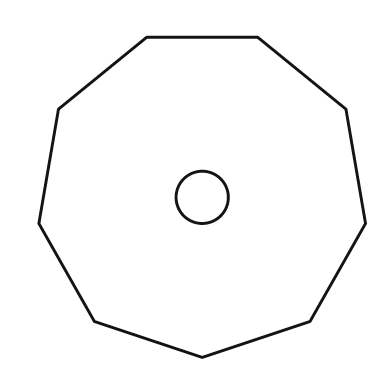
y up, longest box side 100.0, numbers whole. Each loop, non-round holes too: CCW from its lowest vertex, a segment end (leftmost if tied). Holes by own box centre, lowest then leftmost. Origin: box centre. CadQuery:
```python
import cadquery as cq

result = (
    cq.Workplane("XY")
    .moveTo(0.0, -49.0)
    .lineTo(33.0, -38.0)
    .lineTo(50.0, -8.0)
    .lineTo(44.0, 27.0)
    .lineTo(17.0, 49.0)
    .lineTo(-17.0, 49.0)
    .lineTo(-44.0, 27.0)
    .lineTo(-50.0, -8.0)
    .lineTo(-33.0, -38.0)
    .close()
    .moveTo(0.0, 0.0)
    .circle(8.0)
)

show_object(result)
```